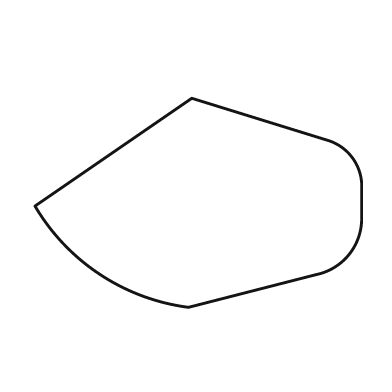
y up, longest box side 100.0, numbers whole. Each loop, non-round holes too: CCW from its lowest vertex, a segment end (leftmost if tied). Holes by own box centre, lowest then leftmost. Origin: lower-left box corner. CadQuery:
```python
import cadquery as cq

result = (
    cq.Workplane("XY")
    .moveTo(47.0, 0.0)
    .lineTo(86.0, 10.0)
    .threePointArc((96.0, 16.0), (100.0, 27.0))
    .lineTo(100.0, 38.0)
    .threePointArc((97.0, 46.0), (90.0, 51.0))
    .lineTo(48.0, 64.0)
    .lineTo(0.0, 31.0)
    .threePointArc((20.0, 10.0), (47.0, 0.0))
    .close()
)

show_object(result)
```